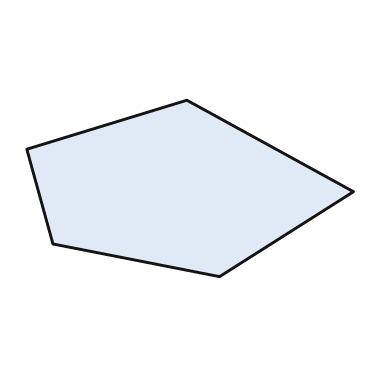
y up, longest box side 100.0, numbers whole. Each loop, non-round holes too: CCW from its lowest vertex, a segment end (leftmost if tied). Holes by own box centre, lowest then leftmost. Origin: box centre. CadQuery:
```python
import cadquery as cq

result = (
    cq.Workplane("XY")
    .moveTo(9.0, -27.0)
    .lineTo(50.0, -1.0)
    .lineTo(-1.0, 27.0)
    .lineTo(-50.0, 12.0)
    .lineTo(-42.0, -17.0)
    .close()
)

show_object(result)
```